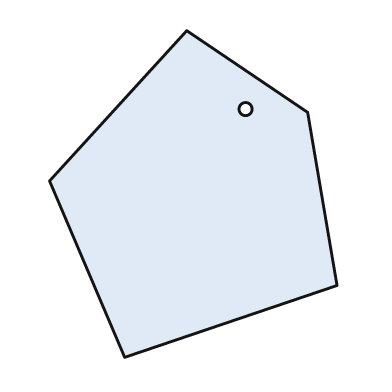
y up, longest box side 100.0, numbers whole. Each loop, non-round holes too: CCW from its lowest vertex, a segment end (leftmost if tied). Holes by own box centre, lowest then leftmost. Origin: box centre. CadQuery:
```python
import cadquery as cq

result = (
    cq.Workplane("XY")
    .moveTo(-21.0, -50.0)
    .lineTo(44.0, -28.0)
    .lineTo(35.0, 25.0)
    .lineTo(-2.0, 50.0)
    .lineTo(-44.0, 4.0)
    .close()
    .moveTo(16.0, 26.0)
    .circle(2.0)
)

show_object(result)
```